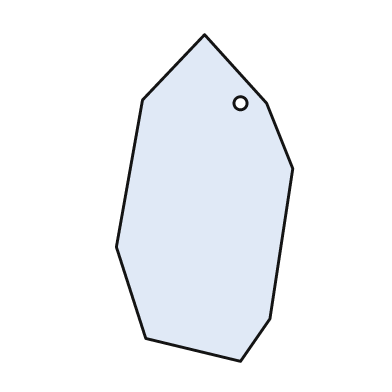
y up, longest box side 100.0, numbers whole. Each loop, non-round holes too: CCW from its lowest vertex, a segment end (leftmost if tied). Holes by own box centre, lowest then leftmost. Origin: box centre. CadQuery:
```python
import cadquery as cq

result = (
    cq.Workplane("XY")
    .moveTo(11.0, -50.0)
    .lineTo(20.0, -37.0)
    .lineTo(27.0, 9.0)
    .lineTo(19.0, 29.0)
    .lineTo(0.0, 50.0)
    .lineTo(-19.0, 30.0)
    .lineTo(-27.0, -15.0)
    .lineTo(-18.0, -43.0)
    .close()
    .moveTo(11.0, 29.0)
    .circle(2.0)
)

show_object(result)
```